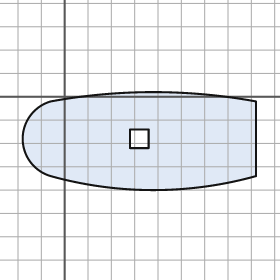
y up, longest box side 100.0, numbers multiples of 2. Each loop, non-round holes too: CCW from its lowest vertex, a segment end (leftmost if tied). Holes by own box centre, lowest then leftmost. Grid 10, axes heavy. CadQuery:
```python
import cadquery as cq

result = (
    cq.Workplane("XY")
    .moveTo(-6.0, -34.0)
    .threePointArc((38.0, -40.0), (82.0, -34.0))
    .lineTo(82.0, -2.0)
    .threePointArc((38.0, 2.0), (-6.0, -2.0))
    .threePointArc((-18.0, -18.0), (-6.0, -34.0))
    .close()
    .moveTo(28.0, -22.0)
    .lineTo(36.0, -22.0)
    .lineTo(36.0, -14.0)
    .lineTo(28.0, -14.0)
    .close()
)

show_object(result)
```